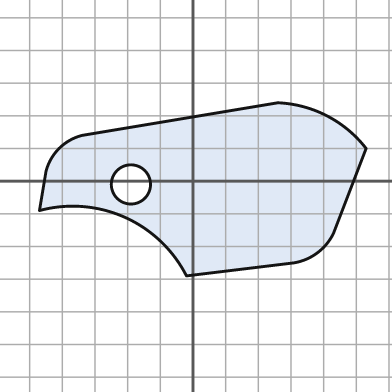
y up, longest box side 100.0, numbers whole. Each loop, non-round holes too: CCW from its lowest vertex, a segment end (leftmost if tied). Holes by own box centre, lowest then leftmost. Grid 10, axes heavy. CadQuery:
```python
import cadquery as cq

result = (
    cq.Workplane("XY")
    .moveTo(-2.0, -29.0)
    .lineTo(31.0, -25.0)
    .threePointArc((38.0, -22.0), (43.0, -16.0))
    .lineTo(53.0, 10.0)
    .threePointArc((41.0, 20.0), (26.0, 24.0))
    .lineTo(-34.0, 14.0)
    .threePointArc((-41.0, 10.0), (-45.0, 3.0))
    .lineTo(-47.0, -9.0)
    .threePointArc((-21.0, -11.0), (-2.0, -29.0))
    .close()
    .moveTo(-19.0, -1.0)
    .circle(6.0)
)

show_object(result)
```